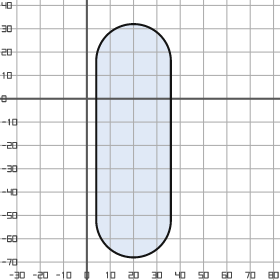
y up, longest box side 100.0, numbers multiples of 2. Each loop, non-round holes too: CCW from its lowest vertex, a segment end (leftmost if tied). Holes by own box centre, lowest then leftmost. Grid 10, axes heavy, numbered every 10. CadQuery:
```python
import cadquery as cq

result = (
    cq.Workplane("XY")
    .moveTo(4.0, -52.0)
    .threePointArc((20.0, -68.0), (36.0, -52.0))
    .lineTo(36.0, 16.0)
    .threePointArc((20.0, 32.0), (4.0, 16.0))
    .close()
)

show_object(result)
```